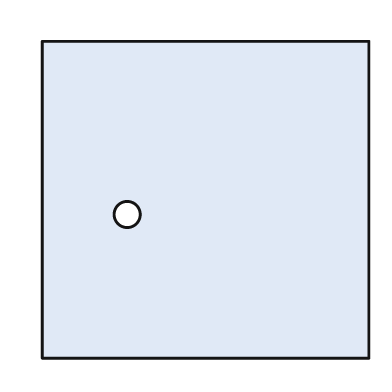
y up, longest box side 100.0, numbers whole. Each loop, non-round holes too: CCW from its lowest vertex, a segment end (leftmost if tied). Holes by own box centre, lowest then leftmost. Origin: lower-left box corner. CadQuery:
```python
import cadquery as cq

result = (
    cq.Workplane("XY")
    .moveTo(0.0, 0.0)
    .lineTo(100.0, 0.0)
    .lineTo(100.0, 97.0)
    .lineTo(0.0, 97.0)
    .close()
    .moveTo(26.0, 44.0)
    .circle(4.0)
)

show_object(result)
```